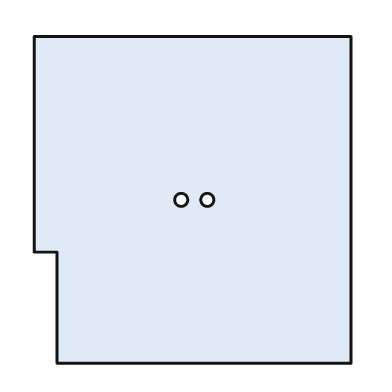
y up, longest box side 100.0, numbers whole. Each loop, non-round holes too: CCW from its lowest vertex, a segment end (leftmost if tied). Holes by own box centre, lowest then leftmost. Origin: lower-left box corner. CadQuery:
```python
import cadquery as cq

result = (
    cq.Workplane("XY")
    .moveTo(7.0, 0.0)
    .lineTo(97.0, 0.0)
    .lineTo(97.0, 100.0)
    .lineTo(0.0, 100.0)
    .lineTo(0.0, 34.0)
    .lineTo(7.0, 34.0)
    .close()
    .moveTo(45.0, 50.0)
    .circle(2.0)
    .moveTo(53.0, 50.0)
    .circle(2.0)
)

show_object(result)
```